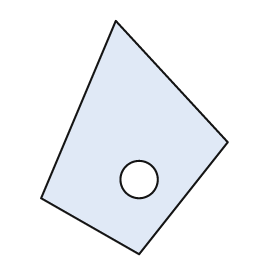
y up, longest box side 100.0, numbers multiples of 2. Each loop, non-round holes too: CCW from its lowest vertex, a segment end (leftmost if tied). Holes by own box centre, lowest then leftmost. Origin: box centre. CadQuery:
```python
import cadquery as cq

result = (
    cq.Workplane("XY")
    .moveTo(2.0, -50.0)
    .lineTo(40.0, -2.0)
    .lineTo(-8.0, 50.0)
    .lineTo(-40.0, -26.0)
    .close()
    .moveTo(2.0, -18.0)
    .circle(8.0)
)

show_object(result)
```